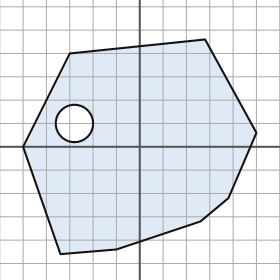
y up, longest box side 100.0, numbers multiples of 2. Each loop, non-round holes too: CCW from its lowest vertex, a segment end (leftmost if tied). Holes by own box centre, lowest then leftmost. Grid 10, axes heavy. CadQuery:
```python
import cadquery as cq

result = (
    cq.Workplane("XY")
    .moveTo(-34.0, -46.0)
    .lineTo(-10.0, -44.0)
    .lineTo(26.0, -32.0)
    .lineTo(38.0, -22.0)
    .lineTo(50.0, 6.0)
    .lineTo(28.0, 46.0)
    .lineTo(-30.0, 40.0)
    .lineTo(-50.0, 0.0)
    .close()
    .moveTo(-28.0, 10.0)
    .circle(8.0)
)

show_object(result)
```